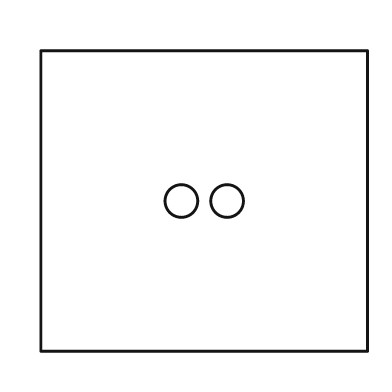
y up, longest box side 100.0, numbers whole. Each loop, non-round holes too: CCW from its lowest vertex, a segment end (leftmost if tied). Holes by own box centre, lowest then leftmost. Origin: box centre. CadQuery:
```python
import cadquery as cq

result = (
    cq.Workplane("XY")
    .moveTo(-50.0, -46.0)
    .lineTo(50.0, -46.0)
    .lineTo(50.0, 46.0)
    .lineTo(-50.0, 46.0)
    .close()
    .moveTo(-7.0, 0.0)
    .circle(5.0)
    .moveTo(7.0, 0.0)
    .circle(5.0)
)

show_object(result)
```